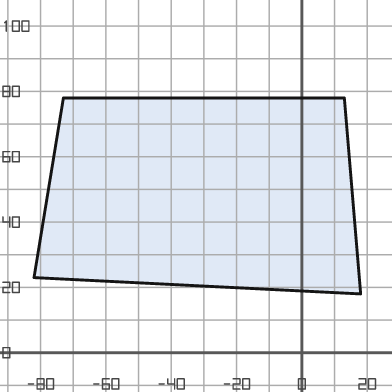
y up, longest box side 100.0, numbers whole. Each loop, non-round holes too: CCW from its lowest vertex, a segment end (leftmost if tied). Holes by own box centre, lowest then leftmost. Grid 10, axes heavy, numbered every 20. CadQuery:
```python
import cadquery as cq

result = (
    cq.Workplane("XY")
    .moveTo(18.0, 18.0)
    .lineTo(13.0, 78.0)
    .lineTo(-73.0, 78.0)
    .lineTo(-82.0, 23.0)
    .close()
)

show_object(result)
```